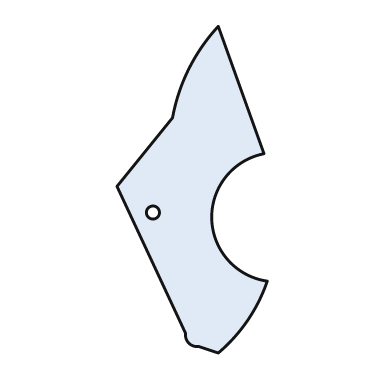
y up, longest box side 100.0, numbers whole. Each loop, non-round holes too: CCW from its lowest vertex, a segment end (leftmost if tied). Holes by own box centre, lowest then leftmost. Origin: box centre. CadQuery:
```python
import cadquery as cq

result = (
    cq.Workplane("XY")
    .moveTo(8.0, -50.0)
    .threePointArc((17.0, -40.0), (23.0, -28.0))
    .threePointArc((6.0, -9.0), (22.0, 11.0))
    .lineTo(8.0, 50.0)
    .threePointArc((-1.0, 37.0), (-6.0, 22.0))
    .lineTo(-23.0, 1.0)
    .lineTo(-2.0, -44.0)
    .threePointArc((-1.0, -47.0), (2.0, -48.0))
    .close()
    .moveTo(-12.0, -7.0)
    .circle(2.0)
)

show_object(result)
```